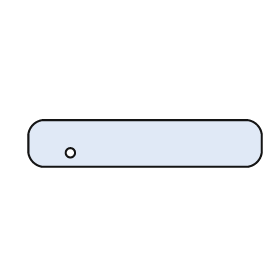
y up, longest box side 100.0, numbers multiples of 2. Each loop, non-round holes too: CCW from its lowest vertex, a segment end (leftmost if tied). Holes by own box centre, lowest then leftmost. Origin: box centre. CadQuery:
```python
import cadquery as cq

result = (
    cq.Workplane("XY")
    .moveTo(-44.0, -10.0)
    .lineTo(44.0, -10.0)
    .threePointArc((48.0, -8.0), (50.0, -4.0))
    .lineTo(50.0, 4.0)
    .threePointArc((48.0, 8.0), (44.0, 10.0))
    .lineTo(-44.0, 10.0)
    .threePointArc((-48.0, 8.0), (-50.0, 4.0))
    .lineTo(-50.0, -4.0)
    .threePointArc((-48.0, -8.0), (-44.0, -10.0))
    .close()
    .moveTo(-32.0, -4.0)
    .circle(2.0)
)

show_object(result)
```